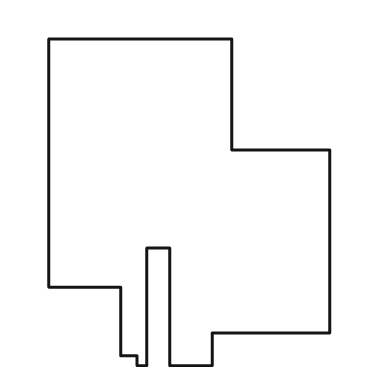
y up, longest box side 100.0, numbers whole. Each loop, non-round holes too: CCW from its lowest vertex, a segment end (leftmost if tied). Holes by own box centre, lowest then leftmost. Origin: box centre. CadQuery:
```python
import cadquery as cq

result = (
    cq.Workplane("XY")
    .moveTo(-16.0, -50.0)
    .lineTo(-13.0, -50.0)
    .lineTo(-13.0, -14.0)
    .lineTo(-6.0, -14.0)
    .lineTo(-6.0, -50.0)
    .lineTo(7.0, -50.0)
    .lineTo(7.0, -40.0)
    .lineTo(43.0, -40.0)
    .lineTo(43.0, 16.0)
    .lineTo(13.0, 16.0)
    .lineTo(13.0, 50.0)
    .lineTo(-43.0, 50.0)
    .lineTo(-43.0, -26.0)
    .lineTo(-21.0, -26.0)
    .lineTo(-21.0, -47.0)
    .lineTo(-16.0, -47.0)
    .close()
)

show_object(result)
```